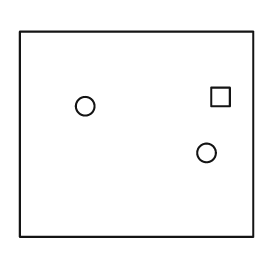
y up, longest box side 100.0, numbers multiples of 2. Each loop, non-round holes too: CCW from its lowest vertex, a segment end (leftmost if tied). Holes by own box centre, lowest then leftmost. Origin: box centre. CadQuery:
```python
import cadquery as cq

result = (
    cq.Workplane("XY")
    .moveTo(-50.0, -44.0)
    .lineTo(50.0, -44.0)
    .lineTo(50.0, 44.0)
    .lineTo(-50.0, 44.0)
    .close()
    .moveTo(30.0, -8.0)
    .circle(4.0)
    .moveTo(-22.0, 12.0)
    .circle(4.0)
    .moveTo(32.0, 12.0)
    .lineTo(40.0, 12.0)
    .lineTo(40.0, 20.0)
    .lineTo(32.0, 20.0)
    .close()
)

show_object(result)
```